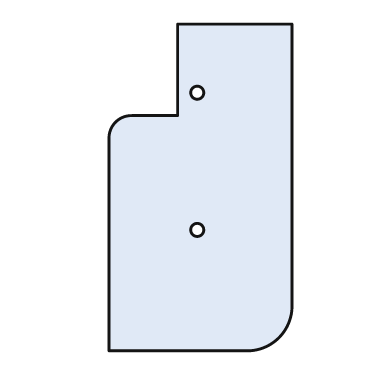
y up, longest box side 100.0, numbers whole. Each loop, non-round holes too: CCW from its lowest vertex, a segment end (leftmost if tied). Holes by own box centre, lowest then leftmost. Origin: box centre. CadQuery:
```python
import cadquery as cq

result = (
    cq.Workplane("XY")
    .moveTo(-28.0, -50.0)
    .lineTo(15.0, -50.0)
    .threePointArc((24.0, -46.0), (28.0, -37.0))
    .lineTo(28.0, 50.0)
    .lineTo(-7.0, 50.0)
    .lineTo(-7.0, 22.0)
    .lineTo(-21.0, 22.0)
    .threePointArc((-26.0, 20.0), (-28.0, 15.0))
    .close()
    .moveTo(-1.0, -13.0)
    .circle(2.0)
    .moveTo(-1.0, 29.0)
    .circle(2.0)
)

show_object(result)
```